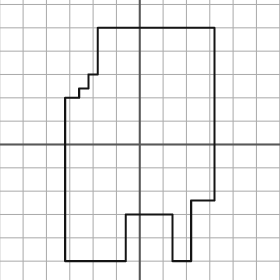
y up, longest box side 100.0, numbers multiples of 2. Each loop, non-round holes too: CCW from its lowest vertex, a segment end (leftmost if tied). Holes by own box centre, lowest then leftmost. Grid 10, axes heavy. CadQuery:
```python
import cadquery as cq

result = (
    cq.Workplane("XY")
    .moveTo(-32.0, -50.0)
    .lineTo(-6.0, -50.0)
    .lineTo(-6.0, -30.0)
    .lineTo(14.0, -30.0)
    .lineTo(14.0, -50.0)
    .lineTo(22.0, -50.0)
    .lineTo(22.0, -24.0)
    .lineTo(32.0, -24.0)
    .lineTo(32.0, 50.0)
    .lineTo(-18.0, 50.0)
    .lineTo(-18.0, 30.0)
    .lineTo(-22.0, 30.0)
    .lineTo(-22.0, 24.0)
    .lineTo(-26.0, 24.0)
    .lineTo(-26.0, 20.0)
    .lineTo(-32.0, 20.0)
    .close()
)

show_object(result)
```